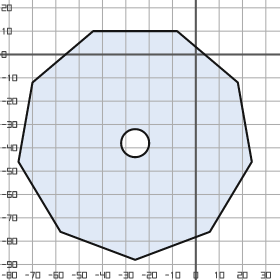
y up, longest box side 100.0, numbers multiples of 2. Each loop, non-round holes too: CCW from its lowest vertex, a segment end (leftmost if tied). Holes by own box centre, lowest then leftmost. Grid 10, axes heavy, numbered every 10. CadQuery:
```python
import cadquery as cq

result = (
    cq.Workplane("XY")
    .moveTo(-26.0, -88.0)
    .lineTo(6.0, -76.0)
    .lineTo(24.0, -46.0)
    .lineTo(18.0, -12.0)
    .lineTo(-8.0, 10.0)
    .lineTo(-44.0, 10.0)
    .lineTo(-70.0, -12.0)
    .lineTo(-76.0, -46.0)
    .lineTo(-58.0, -76.0)
    .close()
    .moveTo(-26.0, -38.0)
    .circle(6.0)
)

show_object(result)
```